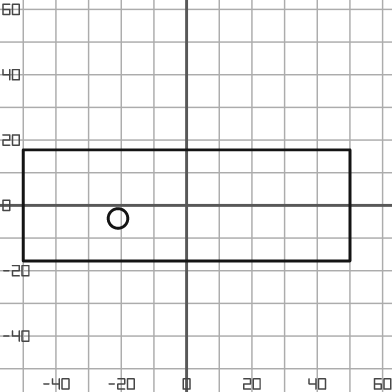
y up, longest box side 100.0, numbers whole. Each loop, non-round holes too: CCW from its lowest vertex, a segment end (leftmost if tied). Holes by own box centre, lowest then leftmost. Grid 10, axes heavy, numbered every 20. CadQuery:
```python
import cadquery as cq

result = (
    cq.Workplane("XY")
    .moveTo(-50.0, -17.0)
    .lineTo(50.0, -17.0)
    .lineTo(50.0, 17.0)
    .lineTo(-50.0, 17.0)
    .close()
    .moveTo(-21.0, -4.0)
    .circle(3.0)
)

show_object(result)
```